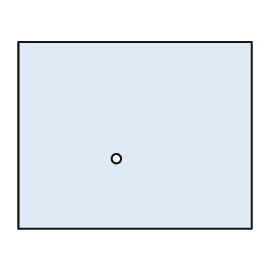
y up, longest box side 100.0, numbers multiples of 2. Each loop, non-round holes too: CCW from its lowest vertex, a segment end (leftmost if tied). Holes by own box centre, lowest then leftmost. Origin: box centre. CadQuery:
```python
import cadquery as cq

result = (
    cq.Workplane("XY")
    .moveTo(-50.0, -40.0)
    .lineTo(50.0, -40.0)
    .lineTo(50.0, 40.0)
    .lineTo(-50.0, 40.0)
    .close()
    .moveTo(-8.0, -10.0)
    .circle(2.0)
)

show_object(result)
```